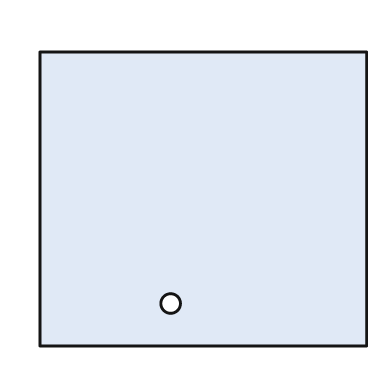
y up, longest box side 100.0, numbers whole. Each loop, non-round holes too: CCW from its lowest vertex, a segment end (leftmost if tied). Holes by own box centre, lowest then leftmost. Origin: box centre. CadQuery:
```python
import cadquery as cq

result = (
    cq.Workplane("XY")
    .moveTo(-50.0, -45.0)
    .lineTo(50.0, -45.0)
    .lineTo(50.0, 45.0)
    .lineTo(-50.0, 45.0)
    .close()
    .moveTo(-10.0, -32.0)
    .circle(3.0)
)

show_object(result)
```